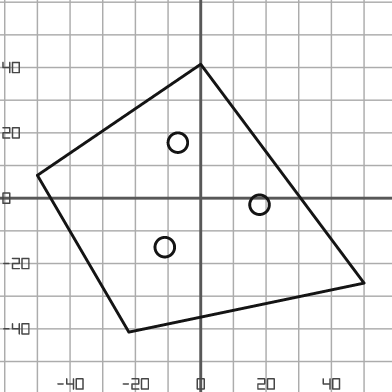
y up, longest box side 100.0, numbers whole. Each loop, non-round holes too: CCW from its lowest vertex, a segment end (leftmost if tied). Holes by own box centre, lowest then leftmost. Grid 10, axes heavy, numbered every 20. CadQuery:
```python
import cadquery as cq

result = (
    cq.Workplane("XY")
    .moveTo(-22.0, -41.0)
    .lineTo(50.0, -26.0)
    .lineTo(0.0, 41.0)
    .lineTo(-50.0, 7.0)
    .close()
    .moveTo(-11.0, -15.0)
    .circle(3.0)
    .moveTo(18.0, -2.0)
    .circle(3.0)
    .moveTo(-7.0, 17.0)
    .circle(3.0)
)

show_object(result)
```